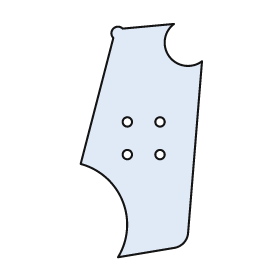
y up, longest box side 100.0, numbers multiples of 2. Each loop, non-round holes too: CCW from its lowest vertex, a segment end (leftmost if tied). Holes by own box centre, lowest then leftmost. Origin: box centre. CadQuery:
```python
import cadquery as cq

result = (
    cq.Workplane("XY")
    .moveTo(-10.0, -50.0)
    .lineTo(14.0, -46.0)
    .threePointArc((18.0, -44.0), (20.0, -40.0))
    .lineTo(26.0, 34.0)
    .threePointArc((12.0, 36.0), (14.0, 50.0))
    .lineTo(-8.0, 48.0)
    .threePointArc((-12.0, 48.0), (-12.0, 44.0))
    .lineTo(-26.0, -10.0)
    .threePointArc((-8.0, -26.0), (-10.0, -50.0))
    .close()
    .moveTo(-6.0, -6.0)
    .circle(2.0)
    .moveTo(8.0, -6.0)
    .circle(2.0)
    .moveTo(-6.0, 8.0)
    .circle(2.0)
    .moveTo(8.0, 8.0)
    .circle(2.0)
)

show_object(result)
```